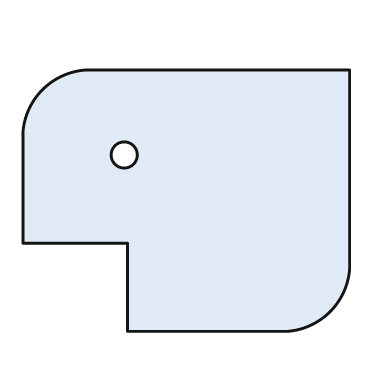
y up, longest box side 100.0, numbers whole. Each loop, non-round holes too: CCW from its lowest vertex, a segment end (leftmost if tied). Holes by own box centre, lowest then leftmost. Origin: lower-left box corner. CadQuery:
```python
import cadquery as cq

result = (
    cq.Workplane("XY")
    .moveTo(32.0, 0.0)
    .lineTo(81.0, 0.0)
    .threePointArc((94.0, 6.0), (100.0, 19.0))
    .lineTo(100.0, 80.0)
    .lineTo(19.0, 80.0)
    .threePointArc((6.0, 74.0), (0.0, 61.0))
    .lineTo(0.0, 27.0)
    .lineTo(32.0, 27.0)
    .close()
    .moveTo(31.0, 54.0)
    .circle(4.0)
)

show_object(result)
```